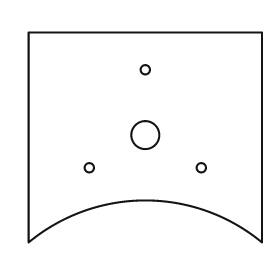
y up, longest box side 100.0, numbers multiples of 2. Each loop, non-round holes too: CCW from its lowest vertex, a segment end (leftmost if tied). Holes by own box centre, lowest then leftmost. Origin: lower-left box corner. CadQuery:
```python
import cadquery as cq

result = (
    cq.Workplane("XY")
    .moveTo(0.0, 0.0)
    .threePointArc((50.0, 18.0), (100.0, 0.0))
    .lineTo(100.0, 90.0)
    .lineTo(0.0, 90.0)
    .close()
    .moveTo(26.0, 32.0)
    .circle(2.0)
    .moveTo(74.0, 32.0)
    .circle(2.0)
    .moveTo(50.0, 46.0)
    .circle(6.0)
    .moveTo(50.0, 74.0)
    .circle(2.0)
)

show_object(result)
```